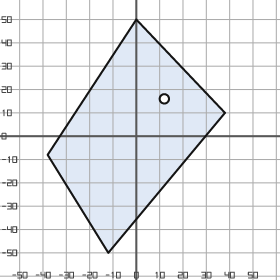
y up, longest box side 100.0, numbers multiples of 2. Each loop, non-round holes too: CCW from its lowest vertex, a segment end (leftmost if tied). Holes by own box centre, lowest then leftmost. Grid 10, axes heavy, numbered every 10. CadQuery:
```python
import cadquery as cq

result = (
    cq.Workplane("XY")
    .moveTo(-12.0, -50.0)
    .lineTo(38.0, 10.0)
    .lineTo(0.0, 50.0)
    .lineTo(-38.0, -8.0)
    .close()
    .moveTo(12.0, 16.0)
    .circle(2.0)
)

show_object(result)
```